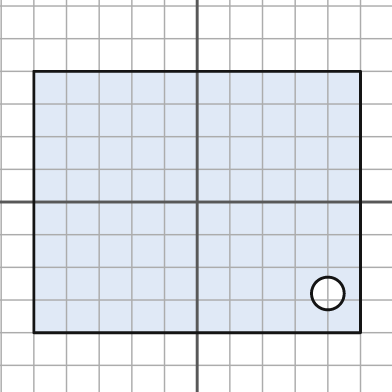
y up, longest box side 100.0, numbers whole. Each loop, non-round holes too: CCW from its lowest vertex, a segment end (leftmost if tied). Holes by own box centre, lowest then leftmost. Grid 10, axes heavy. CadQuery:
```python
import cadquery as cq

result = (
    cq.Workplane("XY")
    .moveTo(-50.0, -40.0)
    .lineTo(50.0, -40.0)
    .lineTo(50.0, 40.0)
    .lineTo(-50.0, 40.0)
    .close()
    .moveTo(40.0, -28.0)
    .circle(5.0)
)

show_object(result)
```